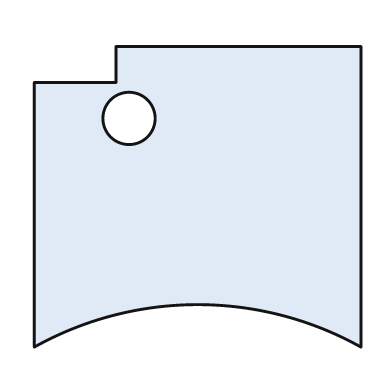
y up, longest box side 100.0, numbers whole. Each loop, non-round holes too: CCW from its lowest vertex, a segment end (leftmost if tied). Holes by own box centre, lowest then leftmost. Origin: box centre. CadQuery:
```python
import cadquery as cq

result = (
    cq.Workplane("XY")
    .moveTo(-50.0, -46.0)
    .threePointArc((0.0, -33.0), (50.0, -46.0))
    .lineTo(50.0, 46.0)
    .lineTo(-25.0, 46.0)
    .lineTo(-25.0, 35.0)
    .lineTo(-50.0, 35.0)
    .close()
    .moveTo(-21.0, 24.0)
    .circle(8.0)
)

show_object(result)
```